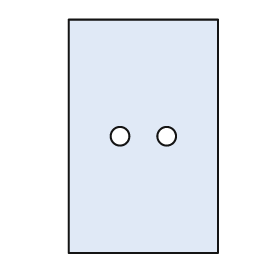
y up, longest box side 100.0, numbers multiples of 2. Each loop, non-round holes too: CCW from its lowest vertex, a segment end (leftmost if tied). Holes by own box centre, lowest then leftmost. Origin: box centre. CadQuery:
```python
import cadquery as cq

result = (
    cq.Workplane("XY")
    .moveTo(-32.0, -50.0)
    .lineTo(32.0, -50.0)
    .lineTo(32.0, 50.0)
    .lineTo(-32.0, 50.0)
    .close()
    .moveTo(-10.0, 0.0)
    .circle(4.0)
    .moveTo(10.0, 0.0)
    .circle(4.0)
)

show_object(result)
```